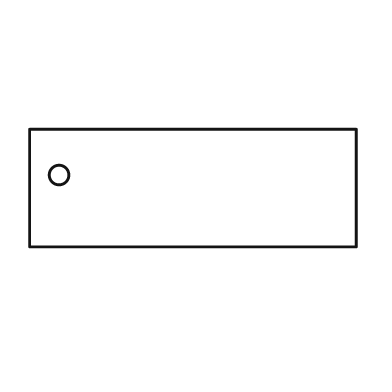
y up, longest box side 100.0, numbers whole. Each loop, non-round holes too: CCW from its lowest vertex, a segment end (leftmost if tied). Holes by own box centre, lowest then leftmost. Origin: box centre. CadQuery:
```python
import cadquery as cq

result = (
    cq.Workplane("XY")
    .moveTo(-50.0, -18.0)
    .lineTo(50.0, -18.0)
    .lineTo(50.0, 18.0)
    .lineTo(-50.0, 18.0)
    .close()
    .moveTo(-41.0, 4.0)
    .circle(3.0)
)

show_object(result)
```